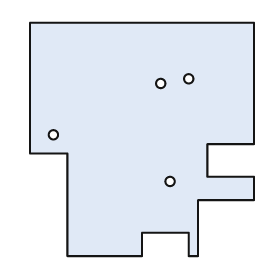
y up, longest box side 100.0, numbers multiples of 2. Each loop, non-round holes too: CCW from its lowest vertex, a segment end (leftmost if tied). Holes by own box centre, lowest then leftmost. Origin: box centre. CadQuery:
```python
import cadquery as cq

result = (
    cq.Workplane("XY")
    .moveTo(-32.0, -50.0)
    .lineTo(0.0, -50.0)
    .lineTo(0.0, -40.0)
    .lineTo(20.0, -40.0)
    .lineTo(20.0, -50.0)
    .lineTo(24.0, -50.0)
    .lineTo(24.0, -26.0)
    .lineTo(48.0, -26.0)
    .lineTo(48.0, -16.0)
    .lineTo(28.0, -16.0)
    .lineTo(28.0, -2.0)
    .lineTo(48.0, -2.0)
    .lineTo(48.0, 50.0)
    .lineTo(-48.0, 50.0)
    .lineTo(-48.0, -6.0)
    .lineTo(-32.0, -6.0)
    .close()
    .moveTo(12.0, -18.0)
    .circle(2.0)
    .moveTo(-38.0, 2.0)
    .circle(2.0)
    .moveTo(8.0, 24.0)
    .circle(2.0)
    .moveTo(20.0, 26.0)
    .circle(2.0)
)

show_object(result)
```